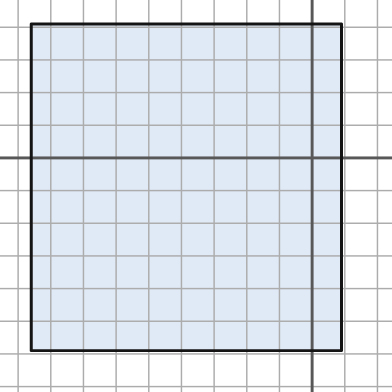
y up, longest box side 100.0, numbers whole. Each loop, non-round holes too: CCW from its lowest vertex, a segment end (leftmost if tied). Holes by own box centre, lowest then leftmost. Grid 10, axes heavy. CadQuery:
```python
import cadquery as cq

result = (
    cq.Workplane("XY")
    .moveTo(-86.0, -59.0)
    .lineTo(9.0, -59.0)
    .lineTo(9.0, 41.0)
    .lineTo(-86.0, 41.0)
    .close()
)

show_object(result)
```